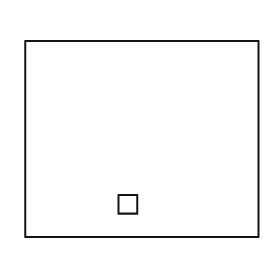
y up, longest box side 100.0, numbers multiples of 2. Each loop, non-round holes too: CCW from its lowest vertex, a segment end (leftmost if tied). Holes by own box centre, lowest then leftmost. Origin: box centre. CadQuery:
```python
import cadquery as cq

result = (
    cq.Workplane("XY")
    .moveTo(-50.0, -42.0)
    .lineTo(50.0, -42.0)
    .lineTo(50.0, 42.0)
    .lineTo(-50.0, 42.0)
    .close()
    .moveTo(-10.0, -32.0)
    .lineTo(-2.0, -32.0)
    .lineTo(-2.0, -24.0)
    .lineTo(-10.0, -24.0)
    .close()
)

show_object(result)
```